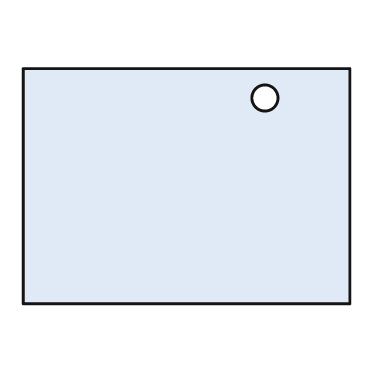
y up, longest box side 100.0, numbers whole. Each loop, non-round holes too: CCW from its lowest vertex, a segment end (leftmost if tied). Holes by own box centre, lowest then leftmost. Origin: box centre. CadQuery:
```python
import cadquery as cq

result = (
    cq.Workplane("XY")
    .moveTo(-50.0, -36.0)
    .lineTo(50.0, -36.0)
    .lineTo(50.0, 36.0)
    .lineTo(-50.0, 36.0)
    .close()
    .moveTo(24.0, 27.0)
    .circle(4.0)
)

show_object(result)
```